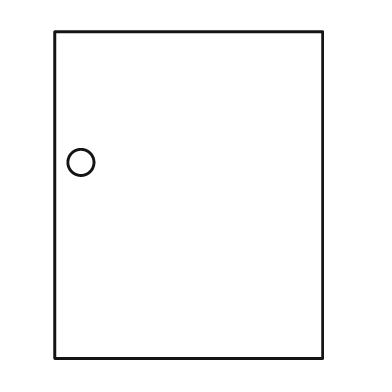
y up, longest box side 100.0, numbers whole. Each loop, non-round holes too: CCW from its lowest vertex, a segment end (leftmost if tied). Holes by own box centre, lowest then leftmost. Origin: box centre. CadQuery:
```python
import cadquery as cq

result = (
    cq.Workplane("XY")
    .moveTo(-41.0, -50.0)
    .lineTo(41.0, -50.0)
    .lineTo(41.0, 50.0)
    .lineTo(-41.0, 50.0)
    .close()
    .moveTo(-33.0, 10.0)
    .circle(4.0)
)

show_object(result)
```